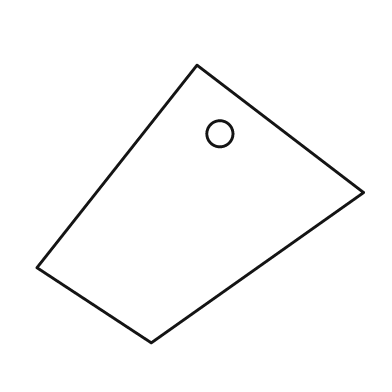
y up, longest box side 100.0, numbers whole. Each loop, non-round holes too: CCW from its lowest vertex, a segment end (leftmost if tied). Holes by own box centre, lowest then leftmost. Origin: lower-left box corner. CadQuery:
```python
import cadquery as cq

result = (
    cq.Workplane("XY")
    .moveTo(35.0, 0.0)
    .lineTo(100.0, 46.0)
    .lineTo(49.0, 85.0)
    .lineTo(0.0, 23.0)
    .close()
    .moveTo(56.0, 64.0)
    .circle(4.0)
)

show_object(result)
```